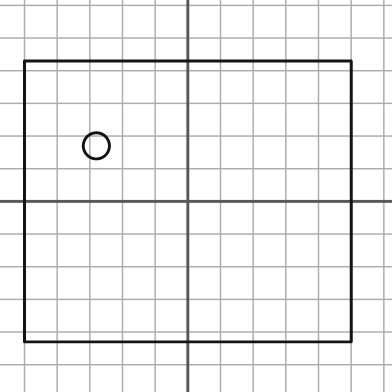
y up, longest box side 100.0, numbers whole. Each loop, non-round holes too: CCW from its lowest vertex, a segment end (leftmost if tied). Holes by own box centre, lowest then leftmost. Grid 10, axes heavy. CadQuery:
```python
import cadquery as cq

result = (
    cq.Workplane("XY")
    .moveTo(-50.0, -43.0)
    .lineTo(50.0, -43.0)
    .lineTo(50.0, 43.0)
    .lineTo(-50.0, 43.0)
    .close()
    .moveTo(-28.0, 17.0)
    .circle(4.0)
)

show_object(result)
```